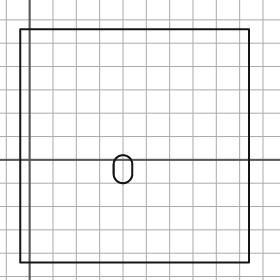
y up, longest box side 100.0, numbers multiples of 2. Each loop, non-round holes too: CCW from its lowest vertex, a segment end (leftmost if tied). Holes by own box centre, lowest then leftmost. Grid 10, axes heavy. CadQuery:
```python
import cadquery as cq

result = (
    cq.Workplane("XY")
    .moveTo(-4.0, -44.0)
    .lineTo(94.0, -44.0)
    .lineTo(94.0, 56.0)
    .lineTo(-4.0, 56.0)
    .close()
    .moveTo(36.0, -6.0)
    .threePointArc((40.0, -10.0), (44.0, -6.0))
    .lineTo(44.0, -2.0)
    .threePointArc((40.0, 2.0), (36.0, -2.0))
    .close()
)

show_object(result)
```